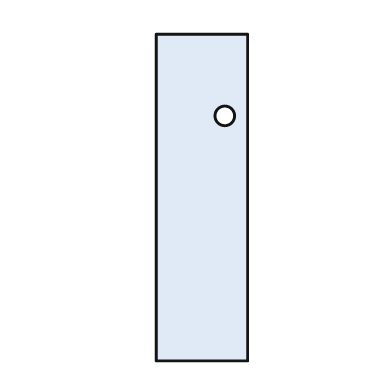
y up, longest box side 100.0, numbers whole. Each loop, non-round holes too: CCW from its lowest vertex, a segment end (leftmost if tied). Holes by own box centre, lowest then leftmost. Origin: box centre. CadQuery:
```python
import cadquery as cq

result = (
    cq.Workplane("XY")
    .moveTo(-14.0, -50.0)
    .lineTo(14.0, -50.0)
    .lineTo(14.0, 50.0)
    .lineTo(-14.0, 50.0)
    .close()
    .moveTo(7.0, 25.0)
    .circle(3.0)
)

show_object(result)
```